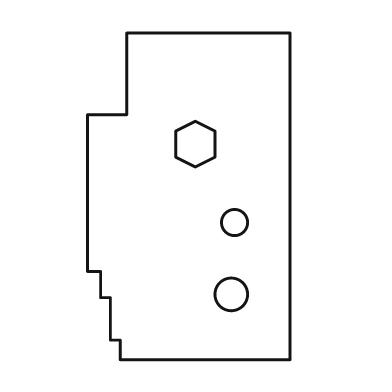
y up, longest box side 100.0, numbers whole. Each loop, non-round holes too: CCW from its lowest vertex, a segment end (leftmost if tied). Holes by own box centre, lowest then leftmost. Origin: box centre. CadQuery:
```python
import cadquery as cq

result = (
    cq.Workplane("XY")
    .moveTo(-21.0, -50.0)
    .lineTo(31.0, -50.0)
    .lineTo(31.0, 50.0)
    .lineTo(-19.0, 50.0)
    .lineTo(-19.0, 25.0)
    .lineTo(-31.0, 25.0)
    .lineTo(-31.0, -23.0)
    .lineTo(-27.0, -23.0)
    .lineTo(-27.0, -31.0)
    .lineTo(-24.0, -31.0)
    .lineTo(-24.0, -44.0)
    .lineTo(-21.0, -44.0)
    .close()
    .moveTo(13.0, -30.0)
    .circle(5.0)
    .moveTo(14.0, -8.0)
    .circle(4.0)
    .moveTo(2.0, 9.0)
    .lineTo(8.0, 12.0)
    .lineTo(8.0, 20.0)
    .lineTo(2.0, 23.0)
    .lineTo(-4.0, 20.0)
    .lineTo(-4.0, 12.0)
    .close()
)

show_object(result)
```